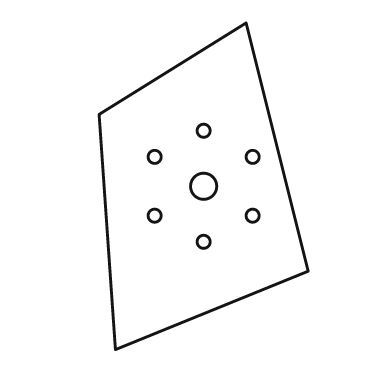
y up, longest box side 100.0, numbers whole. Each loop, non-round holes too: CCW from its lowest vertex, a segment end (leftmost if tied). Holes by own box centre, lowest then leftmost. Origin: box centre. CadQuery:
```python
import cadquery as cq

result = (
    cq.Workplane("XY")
    .moveTo(-27.0, -50.0)
    .lineTo(32.0, -26.0)
    .lineTo(13.0, 50.0)
    .lineTo(-32.0, 22.0)
    .close()
    .moveTo(0.0, -17.0)
    .circle(2.0)
    .moveTo(-15.0, -9.0)
    .circle(2.0)
    .moveTo(15.0, -9.0)
    .circle(2.0)
    .moveTo(0.0, 0.0)
    .circle(4.0)
    .moveTo(-15.0, 9.0)
    .circle(2.0)
    .moveTo(15.0, 9.0)
    .circle(2.0)
    .moveTo(0.0, 17.0)
    .circle(2.0)
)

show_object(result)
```